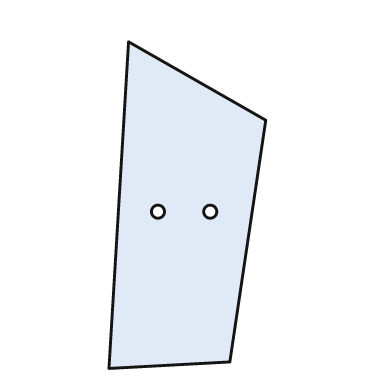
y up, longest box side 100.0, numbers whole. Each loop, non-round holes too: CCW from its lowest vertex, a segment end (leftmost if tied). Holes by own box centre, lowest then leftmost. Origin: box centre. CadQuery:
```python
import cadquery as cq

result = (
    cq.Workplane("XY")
    .moveTo(-24.0, -50.0)
    .lineTo(13.0, -48.0)
    .lineTo(24.0, 26.0)
    .lineTo(-18.0, 50.0)
    .close()
    .moveTo(-9.0, -2.0)
    .circle(2.0)
    .moveTo(7.0, -2.0)
    .circle(2.0)
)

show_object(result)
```